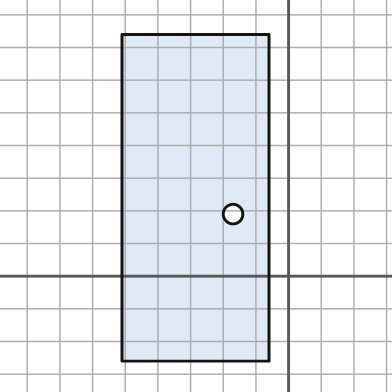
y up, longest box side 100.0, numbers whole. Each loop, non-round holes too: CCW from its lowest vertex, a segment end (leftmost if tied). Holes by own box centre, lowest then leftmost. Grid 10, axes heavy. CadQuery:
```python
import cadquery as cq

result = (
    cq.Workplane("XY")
    .moveTo(-51.0, -26.0)
    .lineTo(-6.0, -26.0)
    .lineTo(-6.0, 74.0)
    .lineTo(-51.0, 74.0)
    .close()
    .moveTo(-17.0, 19.0)
    .circle(3.0)
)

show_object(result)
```